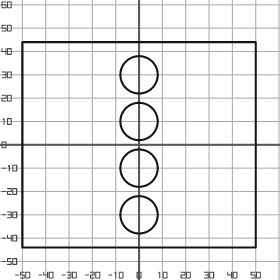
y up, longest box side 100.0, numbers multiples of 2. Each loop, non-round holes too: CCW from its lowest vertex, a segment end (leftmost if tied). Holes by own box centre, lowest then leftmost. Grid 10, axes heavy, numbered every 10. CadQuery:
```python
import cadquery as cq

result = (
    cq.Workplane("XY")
    .moveTo(-50.0, -44.0)
    .lineTo(50.0, -44.0)
    .lineTo(50.0, 44.0)
    .lineTo(-50.0, 44.0)
    .close()
    .moveTo(0.0, -30.0)
    .circle(8.0)
    .moveTo(0.0, -10.0)
    .circle(8.0)
    .moveTo(0.0, 10.0)
    .circle(8.0)
    .moveTo(0.0, 30.0)
    .circle(8.0)
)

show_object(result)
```